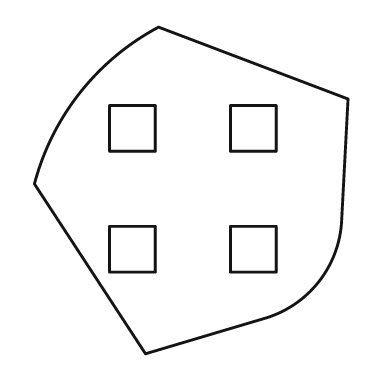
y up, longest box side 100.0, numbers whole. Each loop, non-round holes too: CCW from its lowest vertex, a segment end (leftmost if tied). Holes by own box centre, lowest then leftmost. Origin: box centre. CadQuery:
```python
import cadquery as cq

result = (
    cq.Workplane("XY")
    .moveTo(-14.0, -50.0)
    .lineTo(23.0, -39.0)
    .threePointArc((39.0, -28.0), (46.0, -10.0))
    .lineTo(48.0, 28.0)
    .lineTo(-10.0, 50.0)
    .threePointArc((-34.0, 30.0), (-48.0, 2.0))
    .close()
    .moveTo(-25.0, -25.0)
    .lineTo(-11.0, -25.0)
    .lineTo(-11.0, -11.0)
    .lineTo(-25.0, -11.0)
    .close()
    .moveTo(12.0, -25.0)
    .lineTo(26.0, -25.0)
    .lineTo(26.0, -11.0)
    .lineTo(12.0, -11.0)
    .close()
    .moveTo(-25.0, 12.0)
    .lineTo(-11.0, 12.0)
    .lineTo(-11.0, 26.0)
    .lineTo(-25.0, 26.0)
    .close()
    .moveTo(12.0, 12.0)
    .lineTo(26.0, 12.0)
    .lineTo(26.0, 26.0)
    .lineTo(12.0, 26.0)
    .close()
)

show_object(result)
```